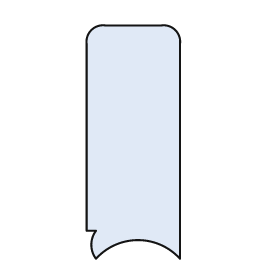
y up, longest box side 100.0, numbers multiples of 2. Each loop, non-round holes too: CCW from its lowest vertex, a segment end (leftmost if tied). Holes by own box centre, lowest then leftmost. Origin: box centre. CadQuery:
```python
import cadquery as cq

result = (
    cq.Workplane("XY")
    .moveTo(-16.0, -50.0)
    .threePointArc((2.0, -42.0), (20.0, -50.0))
    .lineTo(20.0, 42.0)
    .threePointArc((18.0, 48.0), (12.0, 50.0))
    .lineTo(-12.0, 50.0)
    .threePointArc((-18.0, 48.0), (-20.0, 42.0))
    .lineTo(-20.0, -38.0)
    .lineTo(-16.0, -38.0)
    .threePointArc((-18.0, -44.0), (-16.0, -50.0))
    .close()
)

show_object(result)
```